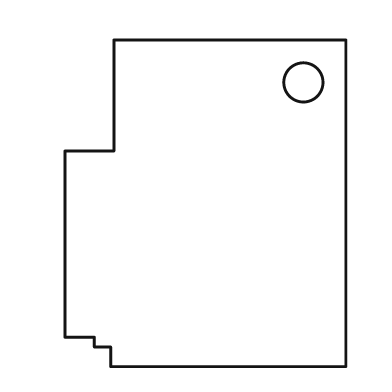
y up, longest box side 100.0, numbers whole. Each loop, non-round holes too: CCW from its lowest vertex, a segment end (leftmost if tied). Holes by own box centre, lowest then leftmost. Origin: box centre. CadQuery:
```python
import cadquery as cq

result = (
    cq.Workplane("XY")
    .moveTo(-29.0, -50.0)
    .lineTo(43.0, -50.0)
    .lineTo(43.0, 50.0)
    .lineTo(-28.0, 50.0)
    .lineTo(-28.0, 16.0)
    .lineTo(-43.0, 16.0)
    .lineTo(-43.0, -41.0)
    .lineTo(-34.0, -41.0)
    .lineTo(-34.0, -44.0)
    .lineTo(-29.0, -44.0)
    .close()
    .moveTo(30.0, 37.0)
    .circle(6.0)
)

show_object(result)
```